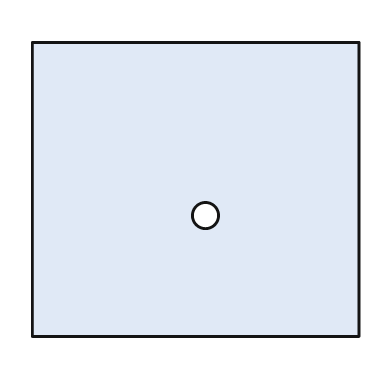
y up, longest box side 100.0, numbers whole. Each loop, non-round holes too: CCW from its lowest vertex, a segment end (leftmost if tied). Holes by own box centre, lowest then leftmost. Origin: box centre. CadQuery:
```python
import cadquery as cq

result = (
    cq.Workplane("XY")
    .moveTo(-50.0, -45.0)
    .lineTo(50.0, -45.0)
    .lineTo(50.0, 45.0)
    .lineTo(-50.0, 45.0)
    .close()
    .moveTo(3.0, -8.0)
    .circle(4.0)
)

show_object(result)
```